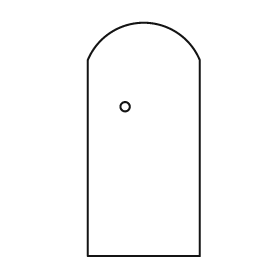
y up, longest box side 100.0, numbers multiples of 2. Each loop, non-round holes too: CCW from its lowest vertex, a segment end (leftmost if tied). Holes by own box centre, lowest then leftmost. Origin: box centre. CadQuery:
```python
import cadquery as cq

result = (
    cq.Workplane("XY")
    .moveTo(-24.0, -50.0)
    .lineTo(24.0, -50.0)
    .lineTo(24.0, 34.0)
    .threePointArc((0.0, 50.0), (-24.0, 34.0))
    .close()
    .moveTo(-8.0, 14.0)
    .circle(2.0)
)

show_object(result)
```